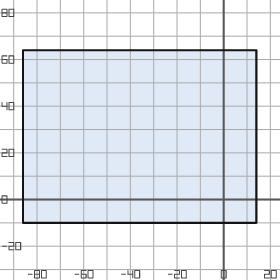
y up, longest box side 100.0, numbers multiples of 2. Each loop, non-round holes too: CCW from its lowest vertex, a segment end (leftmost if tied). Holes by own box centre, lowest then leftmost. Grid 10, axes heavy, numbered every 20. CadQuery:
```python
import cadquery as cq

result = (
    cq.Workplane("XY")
    .moveTo(-86.0, -10.0)
    .lineTo(14.0, -10.0)
    .lineTo(14.0, 64.0)
    .lineTo(-86.0, 64.0)
    .close()
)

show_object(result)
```